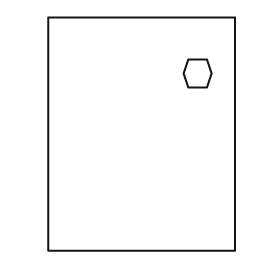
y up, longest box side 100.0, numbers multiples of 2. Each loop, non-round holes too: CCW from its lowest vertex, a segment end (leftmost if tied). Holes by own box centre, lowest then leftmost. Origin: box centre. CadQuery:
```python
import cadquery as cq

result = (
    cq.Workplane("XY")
    .moveTo(-40.0, -50.0)
    .lineTo(40.0, -50.0)
    .lineTo(40.0, 50.0)
    .lineTo(-40.0, 50.0)
    .close()
    .moveTo(20.0, 20.0)
    .lineTo(28.0, 20.0)
    .lineTo(30.0, 26.0)
    .lineTo(28.0, 32.0)
    .lineTo(20.0, 32.0)
    .lineTo(18.0, 26.0)
    .close()
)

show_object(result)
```